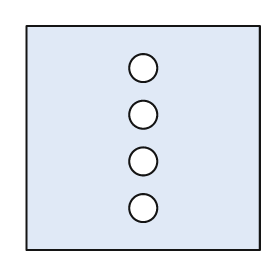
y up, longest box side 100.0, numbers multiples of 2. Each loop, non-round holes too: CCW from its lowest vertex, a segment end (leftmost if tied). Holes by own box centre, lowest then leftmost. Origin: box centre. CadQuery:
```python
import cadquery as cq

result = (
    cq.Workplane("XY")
    .moveTo(-50.0, -48.0)
    .lineTo(50.0, -48.0)
    .lineTo(50.0, 48.0)
    .lineTo(-50.0, 48.0)
    .close()
    .moveTo(0.0, -30.0)
    .circle(6.0)
    .moveTo(0.0, -10.0)
    .circle(6.0)
    .moveTo(0.0, 10.0)
    .circle(6.0)
    .moveTo(0.0, 30.0)
    .circle(6.0)
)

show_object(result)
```